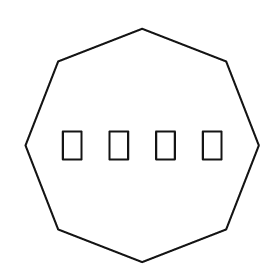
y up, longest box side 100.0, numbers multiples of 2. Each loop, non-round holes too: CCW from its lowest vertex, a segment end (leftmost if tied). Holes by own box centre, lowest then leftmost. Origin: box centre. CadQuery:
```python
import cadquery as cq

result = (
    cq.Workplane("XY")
    .moveTo(0.0, -50.0)
    .lineTo(36.0, -36.0)
    .lineTo(50.0, 0.0)
    .lineTo(36.0, 36.0)
    .lineTo(0.0, 50.0)
    .lineTo(-36.0, 36.0)
    .lineTo(-50.0, 0.0)
    .lineTo(-36.0, -36.0)
    .close()
    .moveTo(-34.0, -6.0)
    .lineTo(-26.0, -6.0)
    .lineTo(-26.0, 6.0)
    .lineTo(-34.0, 6.0)
    .close()
    .moveTo(-14.0, -6.0)
    .lineTo(-6.0, -6.0)
    .lineTo(-6.0, 6.0)
    .lineTo(-14.0, 6.0)
    .close()
    .moveTo(6.0, -6.0)
    .lineTo(14.0, -6.0)
    .lineTo(14.0, 6.0)
    .lineTo(6.0, 6.0)
    .close()
    .moveTo(26.0, -6.0)
    .lineTo(34.0, -6.0)
    .lineTo(34.0, 6.0)
    .lineTo(26.0, 6.0)
    .close()
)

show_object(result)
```